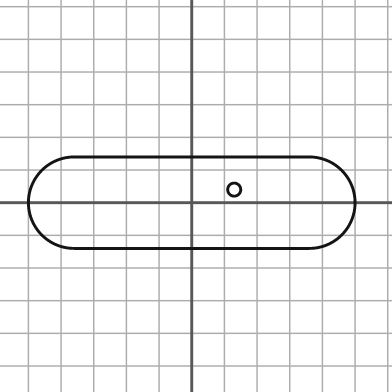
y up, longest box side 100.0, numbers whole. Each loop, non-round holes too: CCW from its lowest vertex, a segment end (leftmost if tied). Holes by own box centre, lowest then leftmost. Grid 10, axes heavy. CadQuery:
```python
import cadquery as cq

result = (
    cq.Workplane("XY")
    .moveTo(-36.0, -14.0)
    .lineTo(36.0, -14.0)
    .threePointArc((50.0, 0.0), (36.0, 14.0))
    .lineTo(-36.0, 14.0)
    .threePointArc((-50.0, 0.0), (-36.0, -14.0))
    .close()
    .moveTo(13.0, 4.0)
    .circle(2.0)
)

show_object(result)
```